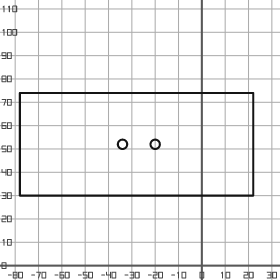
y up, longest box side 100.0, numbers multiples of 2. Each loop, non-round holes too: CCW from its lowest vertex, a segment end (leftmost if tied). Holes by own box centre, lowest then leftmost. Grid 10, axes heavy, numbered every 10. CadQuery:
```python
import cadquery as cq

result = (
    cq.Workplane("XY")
    .moveTo(-78.0, 30.0)
    .lineTo(22.0, 30.0)
    .lineTo(22.0, 74.0)
    .lineTo(-78.0, 74.0)
    .close()
    .moveTo(-34.0, 52.0)
    .circle(2.0)
    .moveTo(-20.0, 52.0)
    .circle(2.0)
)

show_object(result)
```